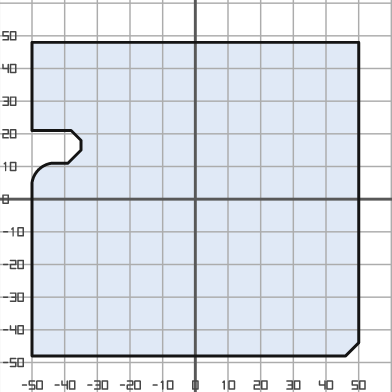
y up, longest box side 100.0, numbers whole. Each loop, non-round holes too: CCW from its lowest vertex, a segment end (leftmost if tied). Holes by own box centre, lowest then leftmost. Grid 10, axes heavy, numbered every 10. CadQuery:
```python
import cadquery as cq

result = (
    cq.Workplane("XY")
    .moveTo(-50.0, -48.0)
    .lineTo(46.0, -48.0)
    .lineTo(50.0, -44.0)
    .lineTo(50.0, 48.0)
    .lineTo(-50.0, 48.0)
    .lineTo(-50.0, 21.0)
    .lineTo(-38.0, 21.0)
    .lineTo(-35.0, 18.0)
    .lineTo(-35.0, 15.0)
    .lineTo(-39.0, 11.0)
    .lineTo(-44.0, 11.0)
    .threePointArc((-48.0, 9.0), (-50.0, 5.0))
    .close()
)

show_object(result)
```